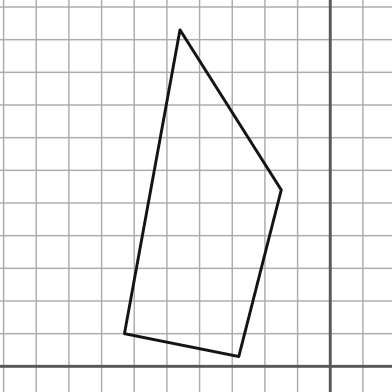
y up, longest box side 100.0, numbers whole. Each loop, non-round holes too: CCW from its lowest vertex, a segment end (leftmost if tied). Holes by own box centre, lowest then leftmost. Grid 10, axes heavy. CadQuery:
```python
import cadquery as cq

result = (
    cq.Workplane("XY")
    .moveTo(-28.0, 3.0)
    .lineTo(-15.0, 54.0)
    .lineTo(-46.0, 103.0)
    .lineTo(-63.0, 10.0)
    .close()
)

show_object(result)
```